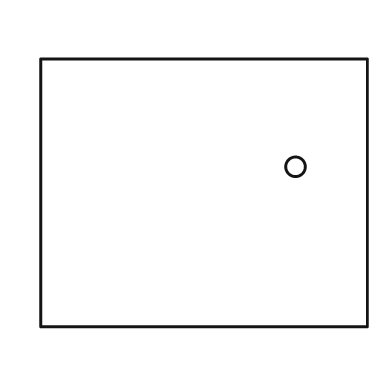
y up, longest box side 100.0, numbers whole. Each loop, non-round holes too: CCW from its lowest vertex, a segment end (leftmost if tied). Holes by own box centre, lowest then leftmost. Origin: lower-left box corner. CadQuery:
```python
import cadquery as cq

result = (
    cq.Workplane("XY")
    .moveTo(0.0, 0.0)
    .lineTo(100.0, 0.0)
    .lineTo(100.0, 82.0)
    .lineTo(0.0, 82.0)
    .close()
    .moveTo(78.0, 49.0)
    .circle(3.0)
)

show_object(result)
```